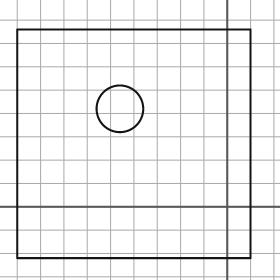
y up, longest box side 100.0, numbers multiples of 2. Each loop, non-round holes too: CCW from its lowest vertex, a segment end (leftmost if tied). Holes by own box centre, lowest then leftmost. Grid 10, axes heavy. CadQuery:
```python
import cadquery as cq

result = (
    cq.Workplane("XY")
    .moveTo(-90.0, -22.0)
    .lineTo(10.0, -22.0)
    .lineTo(10.0, 76.0)
    .lineTo(-90.0, 76.0)
    .close()
    .moveTo(-46.0, 42.0)
    .circle(10.0)
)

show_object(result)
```